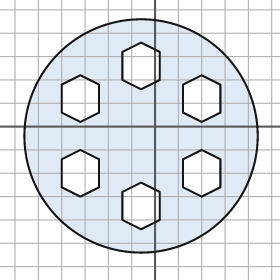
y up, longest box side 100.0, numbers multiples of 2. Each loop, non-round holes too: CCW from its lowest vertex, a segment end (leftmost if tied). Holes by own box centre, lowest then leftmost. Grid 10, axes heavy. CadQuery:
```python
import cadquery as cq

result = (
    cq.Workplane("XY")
    .moveTo(-6.0, -4.0)
    .circle(50.0)
    .moveTo(-6.0, -44.0)
    .lineTo(2.0, -40.0)
    .lineTo(2.0, -28.0)
    .lineTo(-6.0, -24.0)
    .lineTo(-14.0, -28.0)
    .lineTo(-14.0, -40.0)
    .close()
    .moveTo(-32.0, -30.0)
    .lineTo(-24.0, -26.0)
    .lineTo(-24.0, -14.0)
    .lineTo(-32.0, -10.0)
    .lineTo(-40.0, -14.0)
    .lineTo(-40.0, -26.0)
    .close()
    .moveTo(20.0, -30.0)
    .lineTo(28.0, -26.0)
    .lineTo(28.0, -14.0)
    .lineTo(20.0, -10.0)
    .lineTo(12.0, -14.0)
    .lineTo(12.0, -26.0)
    .close()
    .moveTo(-32.0, 2.0)
    .lineTo(-24.0, 6.0)
    .lineTo(-24.0, 18.0)
    .lineTo(-32.0, 22.0)
    .lineTo(-40.0, 18.0)
    .lineTo(-40.0, 6.0)
    .close()
    .moveTo(20.0, 2.0)
    .lineTo(28.0, 6.0)
    .lineTo(28.0, 18.0)
    .lineTo(20.0, 22.0)
    .lineTo(12.0, 18.0)
    .lineTo(12.0, 6.0)
    .close()
    .moveTo(-6.0, 16.0)
    .lineTo(2.0, 20.0)
    .lineTo(2.0, 32.0)
    .lineTo(-6.0, 36.0)
    .lineTo(-14.0, 32.0)
    .lineTo(-14.0, 20.0)
    .close()
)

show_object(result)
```